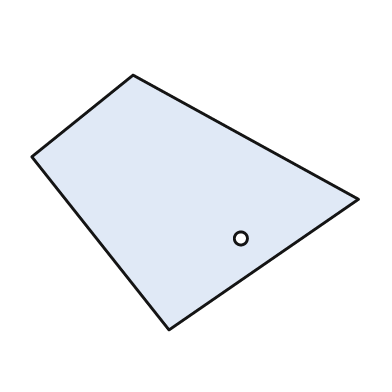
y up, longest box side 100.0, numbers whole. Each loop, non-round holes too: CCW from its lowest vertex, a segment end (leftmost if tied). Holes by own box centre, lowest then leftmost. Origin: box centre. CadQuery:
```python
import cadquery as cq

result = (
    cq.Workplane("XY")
    .moveTo(-8.0, -39.0)
    .lineTo(50.0, 1.0)
    .lineTo(-19.0, 39.0)
    .lineTo(-50.0, 14.0)
    .close()
    .moveTo(14.0, -11.0)
    .circle(2.0)
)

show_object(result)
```